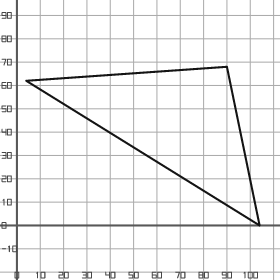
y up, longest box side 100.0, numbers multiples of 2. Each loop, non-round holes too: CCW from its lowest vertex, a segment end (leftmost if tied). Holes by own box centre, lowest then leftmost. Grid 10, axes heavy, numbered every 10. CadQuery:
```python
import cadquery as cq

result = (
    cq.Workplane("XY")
    .moveTo(104.0, 0.0)
    .lineTo(90.0, 68.0)
    .lineTo(4.0, 62.0)
    .close()
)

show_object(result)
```